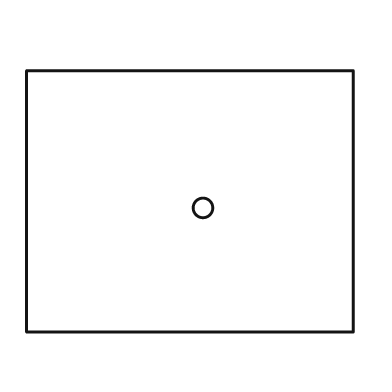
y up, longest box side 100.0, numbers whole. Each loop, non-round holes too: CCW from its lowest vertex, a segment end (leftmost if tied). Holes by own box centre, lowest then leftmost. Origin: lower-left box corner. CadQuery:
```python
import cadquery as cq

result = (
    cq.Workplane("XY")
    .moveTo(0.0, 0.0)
    .lineTo(100.0, 0.0)
    .lineTo(100.0, 80.0)
    .lineTo(0.0, 80.0)
    .close()
    .moveTo(54.0, 38.0)
    .circle(3.0)
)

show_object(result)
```